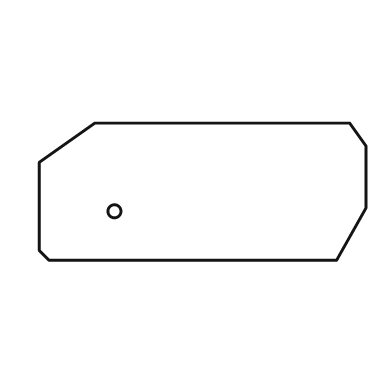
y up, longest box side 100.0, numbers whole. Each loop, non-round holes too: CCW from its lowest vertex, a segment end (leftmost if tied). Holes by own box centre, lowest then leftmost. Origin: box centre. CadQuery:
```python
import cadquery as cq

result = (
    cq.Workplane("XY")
    .moveTo(-47.0, -21.0)
    .lineTo(41.0, -21.0)
    .lineTo(50.0, -5.0)
    .lineTo(50.0, 14.0)
    .lineTo(45.0, 21.0)
    .lineTo(-33.0, 21.0)
    .lineTo(-50.0, 9.0)
    .lineTo(-50.0, -18.0)
    .close()
    .moveTo(-27.0, -6.0)
    .circle(2.0)
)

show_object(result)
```